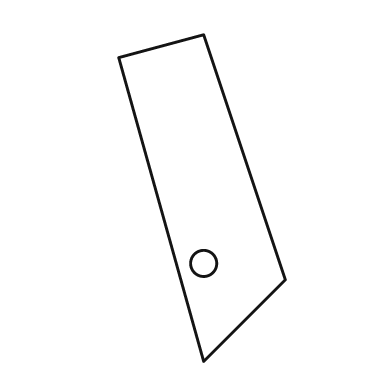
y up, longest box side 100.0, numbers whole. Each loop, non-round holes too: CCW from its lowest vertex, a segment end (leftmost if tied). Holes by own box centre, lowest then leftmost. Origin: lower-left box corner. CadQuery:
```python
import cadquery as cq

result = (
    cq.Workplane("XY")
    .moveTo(26.0, 0.0)
    .lineTo(51.0, 25.0)
    .lineTo(26.0, 100.0)
    .lineTo(0.0, 93.0)
    .close()
    .moveTo(26.0, 30.0)
    .circle(4.0)
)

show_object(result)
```